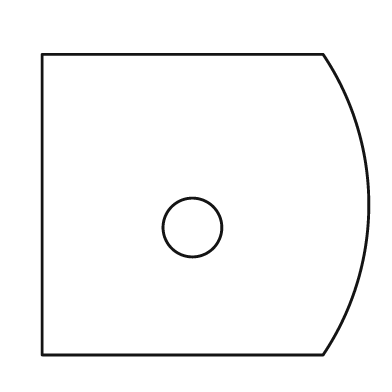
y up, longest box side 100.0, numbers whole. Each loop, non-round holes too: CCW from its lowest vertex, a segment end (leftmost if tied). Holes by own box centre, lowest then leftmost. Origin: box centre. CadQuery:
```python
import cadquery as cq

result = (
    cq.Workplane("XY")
    .moveTo(-50.0, -46.0)
    .lineTo(36.0, -46.0)
    .threePointArc((50.0, 0.0), (36.0, 46.0))
    .lineTo(-50.0, 46.0)
    .close()
    .moveTo(-4.0, -7.0)
    .circle(9.0)
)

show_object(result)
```